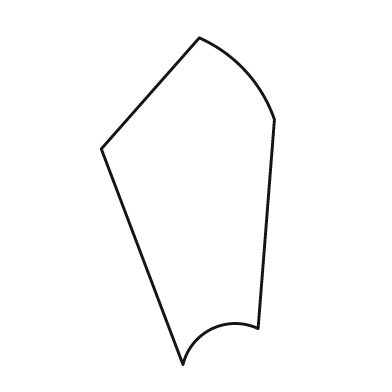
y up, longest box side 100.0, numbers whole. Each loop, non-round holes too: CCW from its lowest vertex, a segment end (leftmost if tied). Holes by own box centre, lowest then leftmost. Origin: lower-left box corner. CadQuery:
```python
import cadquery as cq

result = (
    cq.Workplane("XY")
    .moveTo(25.0, 0.0)
    .threePointArc((34.0, 11.0), (48.0, 11.0))
    .lineTo(53.0, 75.0)
    .threePointArc((44.0, 90.0), (30.0, 100.0))
    .lineTo(0.0, 66.0)
    .close()
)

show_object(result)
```